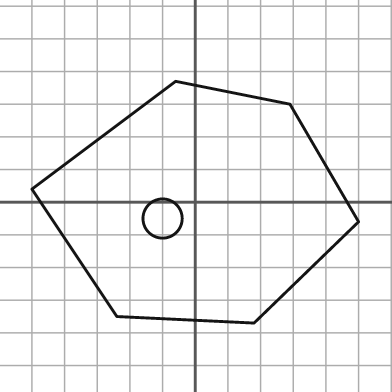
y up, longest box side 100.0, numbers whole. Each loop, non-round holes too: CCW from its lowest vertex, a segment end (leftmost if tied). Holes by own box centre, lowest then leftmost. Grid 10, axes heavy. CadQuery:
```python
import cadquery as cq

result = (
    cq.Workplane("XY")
    .moveTo(18.0, -37.0)
    .lineTo(50.0, -6.0)
    .lineTo(29.0, 30.0)
    .lineTo(-6.0, 37.0)
    .lineTo(-50.0, 4.0)
    .lineTo(-24.0, -35.0)
    .close()
    .moveTo(-10.0, -5.0)
    .circle(6.0)
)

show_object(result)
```